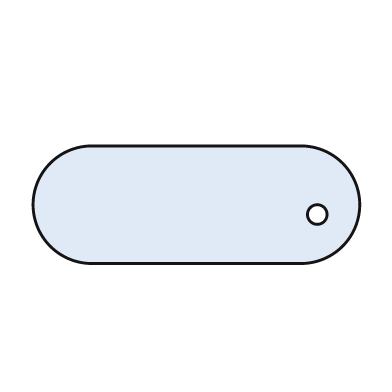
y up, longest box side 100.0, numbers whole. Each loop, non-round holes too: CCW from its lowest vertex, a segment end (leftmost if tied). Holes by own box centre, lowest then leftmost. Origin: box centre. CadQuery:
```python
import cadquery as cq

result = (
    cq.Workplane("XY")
    .moveTo(-32.0, -18.0)
    .lineTo(32.0, -18.0)
    .threePointArc((50.0, 0.0), (32.0, 18.0))
    .lineTo(-32.0, 18.0)
    .threePointArc((-50.0, 0.0), (-32.0, -18.0))
    .close()
    .moveTo(37.0, -3.0)
    .circle(3.0)
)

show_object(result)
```